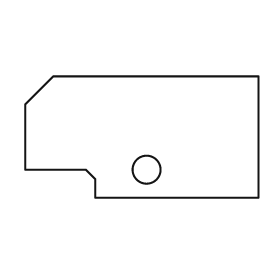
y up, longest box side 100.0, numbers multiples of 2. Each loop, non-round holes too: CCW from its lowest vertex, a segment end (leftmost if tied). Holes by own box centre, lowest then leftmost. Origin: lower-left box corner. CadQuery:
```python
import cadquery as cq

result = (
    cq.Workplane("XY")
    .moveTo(30.0, 0.0)
    .lineTo(100.0, 0.0)
    .lineTo(100.0, 52.0)
    .lineTo(12.0, 52.0)
    .lineTo(0.0, 40.0)
    .lineTo(0.0, 12.0)
    .lineTo(26.0, 12.0)
    .lineTo(30.0, 8.0)
    .close()
    .moveTo(52.0, 12.0)
    .circle(6.0)
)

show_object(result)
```